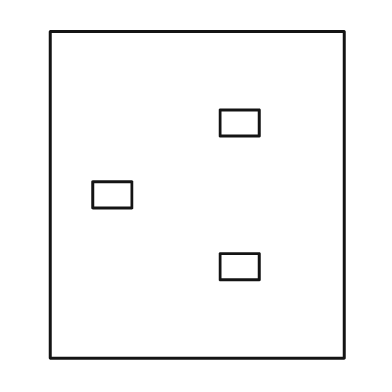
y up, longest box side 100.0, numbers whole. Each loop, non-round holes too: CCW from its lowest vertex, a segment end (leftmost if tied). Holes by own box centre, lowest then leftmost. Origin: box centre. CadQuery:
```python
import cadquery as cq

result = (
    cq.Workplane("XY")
    .moveTo(-45.0, -50.0)
    .lineTo(45.0, -50.0)
    .lineTo(45.0, 50.0)
    .lineTo(-45.0, 50.0)
    .close()
    .moveTo(7.0, -26.0)
    .lineTo(19.0, -26.0)
    .lineTo(19.0, -18.0)
    .lineTo(7.0, -18.0)
    .close()
    .moveTo(-32.0, -4.0)
    .lineTo(-20.0, -4.0)
    .lineTo(-20.0, 4.0)
    .lineTo(-32.0, 4.0)
    .close()
    .moveTo(7.0, 18.0)
    .lineTo(19.0, 18.0)
    .lineTo(19.0, 26.0)
    .lineTo(7.0, 26.0)
    .close()
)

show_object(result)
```